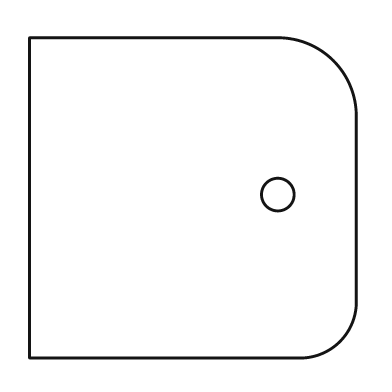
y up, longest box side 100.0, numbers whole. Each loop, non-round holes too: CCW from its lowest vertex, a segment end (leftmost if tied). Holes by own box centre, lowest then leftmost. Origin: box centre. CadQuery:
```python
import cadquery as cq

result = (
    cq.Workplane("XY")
    .moveTo(-50.0, -49.0)
    .lineTo(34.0, -49.0)
    .threePointArc((45.0, -44.0), (50.0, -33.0))
    .lineTo(50.0, 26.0)
    .threePointArc((43.0, 42.0), (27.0, 49.0))
    .lineTo(-50.0, 49.0)
    .close()
    .moveTo(26.0, 1.0)
    .circle(5.0)
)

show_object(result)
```